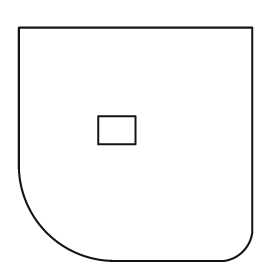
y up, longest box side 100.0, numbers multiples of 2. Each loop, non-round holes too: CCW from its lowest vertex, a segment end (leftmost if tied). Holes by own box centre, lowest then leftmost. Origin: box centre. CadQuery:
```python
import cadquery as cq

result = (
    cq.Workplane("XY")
    .moveTo(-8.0, -50.0)
    .lineTo(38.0, -50.0)
    .threePointArc((46.0, -46.0), (50.0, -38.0))
    .lineTo(50.0, 50.0)
    .lineTo(-50.0, 50.0)
    .lineTo(-50.0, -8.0)
    .threePointArc((-38.0, -38.0), (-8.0, -50.0))
    .close()
    .moveTo(-16.0, 0.0)
    .lineTo(0.0, 0.0)
    .lineTo(0.0, 12.0)
    .lineTo(-16.0, 12.0)
    .close()
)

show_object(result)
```